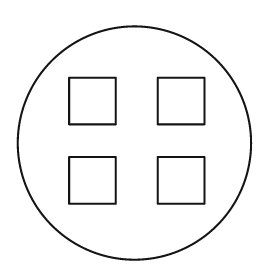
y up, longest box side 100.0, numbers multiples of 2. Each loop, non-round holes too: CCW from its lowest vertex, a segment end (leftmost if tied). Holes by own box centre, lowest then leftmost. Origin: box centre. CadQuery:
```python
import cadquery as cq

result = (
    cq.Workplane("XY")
    .moveTo(0.0, 0.0)
    .circle(50.0)
    .moveTo(-28.0, -26.0)
    .lineTo(-8.0, -26.0)
    .lineTo(-8.0, -6.0)
    .lineTo(-28.0, -6.0)
    .close()
    .moveTo(10.0, -26.0)
    .lineTo(30.0, -26.0)
    .lineTo(30.0, -6.0)
    .lineTo(10.0, -6.0)
    .close()
    .moveTo(-28.0, 8.0)
    .lineTo(-8.0, 8.0)
    .lineTo(-8.0, 28.0)
    .lineTo(-28.0, 28.0)
    .close()
    .moveTo(10.0, 8.0)
    .lineTo(30.0, 8.0)
    .lineTo(30.0, 28.0)
    .lineTo(10.0, 28.0)
    .close()
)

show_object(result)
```